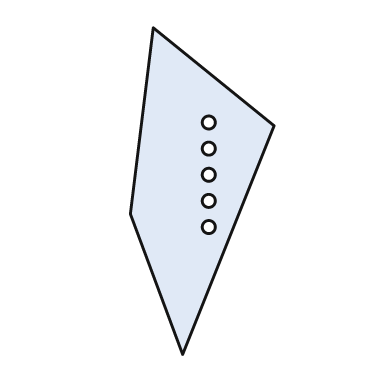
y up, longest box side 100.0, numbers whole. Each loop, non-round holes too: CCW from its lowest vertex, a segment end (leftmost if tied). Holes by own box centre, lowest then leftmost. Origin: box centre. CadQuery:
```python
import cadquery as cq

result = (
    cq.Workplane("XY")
    .moveTo(-6.0, -50.0)
    .lineTo(22.0, 20.0)
    .lineTo(-15.0, 50.0)
    .lineTo(-22.0, -7.0)
    .close()
    .moveTo(2.0, -11.0)
    .circle(2.0)
    .moveTo(2.0, -3.0)
    .circle(2.0)
    .moveTo(2.0, 5.0)
    .circle(2.0)
    .moveTo(2.0, 13.0)
    .circle(2.0)
    .moveTo(2.0, 21.0)
    .circle(2.0)
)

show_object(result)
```